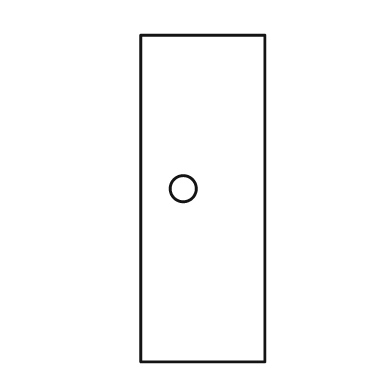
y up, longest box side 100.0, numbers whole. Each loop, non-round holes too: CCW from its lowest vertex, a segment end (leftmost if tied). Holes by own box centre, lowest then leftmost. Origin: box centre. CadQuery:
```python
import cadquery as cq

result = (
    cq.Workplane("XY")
    .moveTo(-19.0, -50.0)
    .lineTo(19.0, -50.0)
    .lineTo(19.0, 50.0)
    .lineTo(-19.0, 50.0)
    .close()
    .moveTo(-6.0, 3.0)
    .circle(4.0)
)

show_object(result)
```